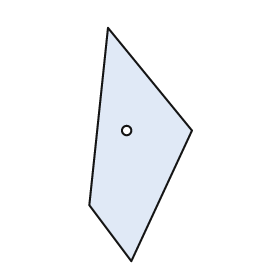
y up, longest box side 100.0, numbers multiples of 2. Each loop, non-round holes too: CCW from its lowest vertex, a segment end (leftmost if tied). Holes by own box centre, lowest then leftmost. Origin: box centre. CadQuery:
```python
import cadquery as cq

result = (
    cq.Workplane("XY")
    .moveTo(-4.0, -50.0)
    .lineTo(22.0, 6.0)
    .lineTo(-14.0, 50.0)
    .lineTo(-22.0, -26.0)
    .close()
    .moveTo(-6.0, 6.0)
    .circle(2.0)
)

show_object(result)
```